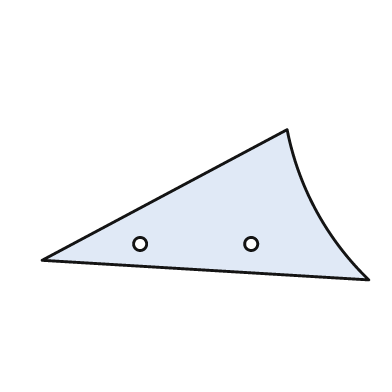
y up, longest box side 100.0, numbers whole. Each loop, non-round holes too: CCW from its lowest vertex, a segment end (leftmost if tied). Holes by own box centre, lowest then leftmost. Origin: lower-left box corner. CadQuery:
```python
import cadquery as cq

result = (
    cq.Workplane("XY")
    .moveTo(100.0, 0.0)
    .threePointArc((84.0, 21.0), (75.0, 46.0))
    .lineTo(0.0, 6.0)
    .close()
    .moveTo(30.0, 11.0)
    .circle(2.0)
    .moveTo(64.0, 11.0)
    .circle(2.0)
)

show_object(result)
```